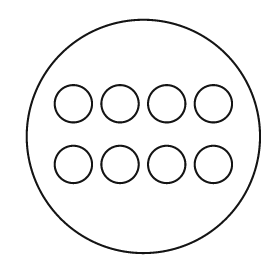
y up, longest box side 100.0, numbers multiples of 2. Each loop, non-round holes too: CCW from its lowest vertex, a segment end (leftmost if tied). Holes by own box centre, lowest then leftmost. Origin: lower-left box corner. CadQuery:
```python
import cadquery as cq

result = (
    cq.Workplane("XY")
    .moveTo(50.0, 50.0)
    .circle(50.0)
    .moveTo(20.0, 38.0)
    .circle(8.0)
    .moveTo(40.0, 38.0)
    .circle(8.0)
    .moveTo(60.0, 38.0)
    .circle(8.0)
    .moveTo(80.0, 38.0)
    .circle(8.0)
    .moveTo(20.0, 64.0)
    .circle(8.0)
    .moveTo(40.0, 64.0)
    .circle(8.0)
    .moveTo(60.0, 64.0)
    .circle(8.0)
    .moveTo(80.0, 64.0)
    .circle(8.0)
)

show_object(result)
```